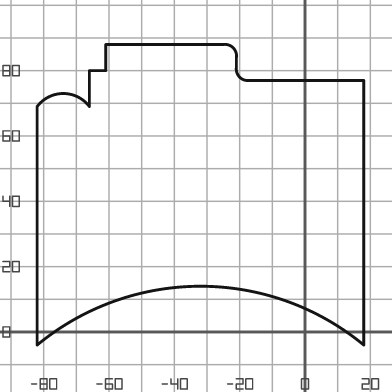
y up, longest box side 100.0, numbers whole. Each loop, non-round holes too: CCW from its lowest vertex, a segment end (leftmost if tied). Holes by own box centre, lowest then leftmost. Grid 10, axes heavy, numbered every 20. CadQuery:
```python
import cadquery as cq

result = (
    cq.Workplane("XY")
    .moveTo(-82.0, -4.0)
    .threePointArc((-32.0, 14.0), (18.0, -4.0))
    .lineTo(18.0, 77.0)
    .lineTo(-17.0, 77.0)
    .threePointArc((-20.0, 78.0), (-21.0, 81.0))
    .lineTo(-21.0, 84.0)
    .threePointArc((-22.0, 87.0), (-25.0, 88.0))
    .lineTo(-61.0, 88.0)
    .lineTo(-61.0, 80.0)
    .lineTo(-66.0, 80.0)
    .lineTo(-66.0, 69.0)
    .threePointArc((-74.0, 73.0), (-82.0, 69.0))
    .close()
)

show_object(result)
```